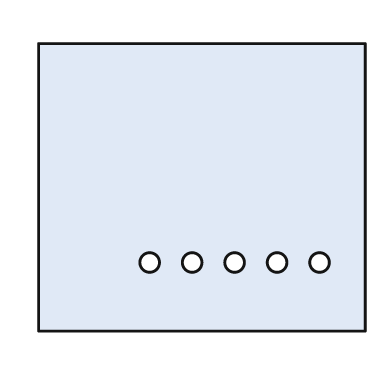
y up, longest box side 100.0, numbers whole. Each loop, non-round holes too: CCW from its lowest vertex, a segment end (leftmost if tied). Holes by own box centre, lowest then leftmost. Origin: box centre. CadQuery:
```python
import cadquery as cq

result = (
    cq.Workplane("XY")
    .moveTo(-50.0, -44.0)
    .lineTo(50.0, -44.0)
    .lineTo(50.0, 44.0)
    .lineTo(-50.0, 44.0)
    .close()
    .moveTo(-16.0, -23.0)
    .circle(3.0)
    .moveTo(-3.0, -23.0)
    .circle(3.0)
    .moveTo(10.0, -23.0)
    .circle(3.0)
    .moveTo(23.0, -23.0)
    .circle(3.0)
    .moveTo(36.0, -23.0)
    .circle(3.0)
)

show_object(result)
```